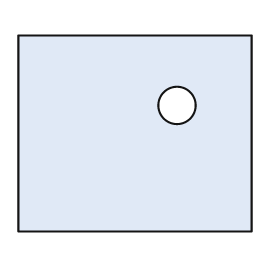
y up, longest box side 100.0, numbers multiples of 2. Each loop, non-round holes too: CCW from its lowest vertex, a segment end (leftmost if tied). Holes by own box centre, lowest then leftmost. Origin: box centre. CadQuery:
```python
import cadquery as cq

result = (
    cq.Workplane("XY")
    .moveTo(-50.0, -42.0)
    .lineTo(50.0, -42.0)
    .lineTo(50.0, 42.0)
    .lineTo(-50.0, 42.0)
    .close()
    .moveTo(18.0, 12.0)
    .circle(8.0)
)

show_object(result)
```